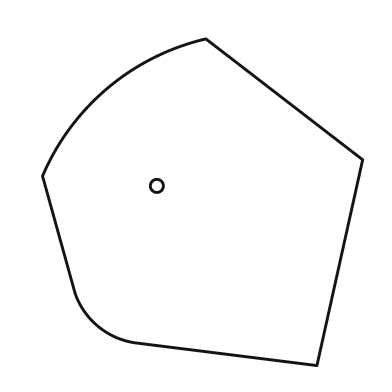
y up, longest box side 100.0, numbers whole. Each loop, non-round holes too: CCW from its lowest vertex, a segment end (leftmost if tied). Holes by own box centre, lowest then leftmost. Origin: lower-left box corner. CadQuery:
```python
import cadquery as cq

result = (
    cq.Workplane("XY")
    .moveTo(84.0, 0.0)
    .lineTo(98.0, 63.0)
    .lineTo(50.0, 100.0)
    .threePointArc((20.0, 85.0), (0.0, 58.0))
    .lineTo(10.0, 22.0)
    .threePointArc((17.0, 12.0), (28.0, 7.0))
    .close()
    .moveTo(35.0, 55.0)
    .circle(2.0)
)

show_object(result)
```